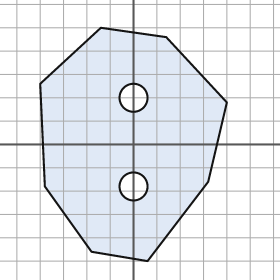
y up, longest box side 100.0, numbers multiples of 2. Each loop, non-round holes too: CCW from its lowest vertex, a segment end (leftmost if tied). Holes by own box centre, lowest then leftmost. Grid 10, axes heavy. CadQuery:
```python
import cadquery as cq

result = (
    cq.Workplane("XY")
    .moveTo(6.0, -50.0)
    .lineTo(32.0, -16.0)
    .lineTo(40.0, 18.0)
    .lineTo(14.0, 46.0)
    .lineTo(-14.0, 50.0)
    .lineTo(-40.0, 26.0)
    .lineTo(-38.0, -18.0)
    .lineTo(-18.0, -46.0)
    .close()
    .moveTo(0.0, -18.0)
    .circle(6.0)
    .moveTo(0.0, 20.0)
    .circle(6.0)
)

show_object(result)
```